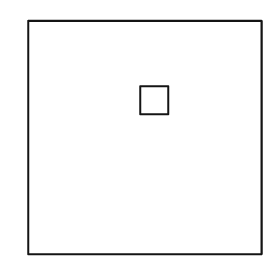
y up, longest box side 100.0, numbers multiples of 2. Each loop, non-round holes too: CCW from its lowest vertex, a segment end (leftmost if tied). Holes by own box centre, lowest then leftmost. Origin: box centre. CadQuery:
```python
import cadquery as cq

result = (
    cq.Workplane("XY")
    .moveTo(-50.0, -50.0)
    .lineTo(50.0, -50.0)
    .lineTo(50.0, 50.0)
    .lineTo(-50.0, 50.0)
    .close()
    .moveTo(-2.0, 10.0)
    .lineTo(10.0, 10.0)
    .lineTo(10.0, 22.0)
    .lineTo(-2.0, 22.0)
    .close()
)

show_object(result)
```